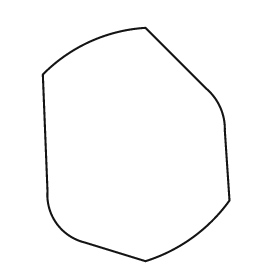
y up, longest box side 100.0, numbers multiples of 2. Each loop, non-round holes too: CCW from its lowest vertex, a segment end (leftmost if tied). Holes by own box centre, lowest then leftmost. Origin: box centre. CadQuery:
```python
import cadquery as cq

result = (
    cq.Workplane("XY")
    .moveTo(4.0, -50.0)
    .threePointArc((24.0, -40.0), (40.0, -24.0))
    .lineTo(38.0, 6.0)
    .threePointArc((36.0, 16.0), (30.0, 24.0))
    .lineTo(4.0, 50.0)
    .threePointArc((-20.0, 44.0), (-40.0, 30.0))
    .lineTo(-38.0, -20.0)
    .threePointArc((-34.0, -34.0), (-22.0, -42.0))
    .close()
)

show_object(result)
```